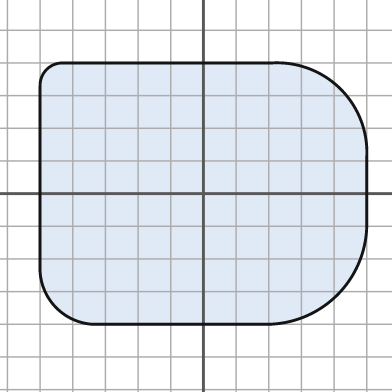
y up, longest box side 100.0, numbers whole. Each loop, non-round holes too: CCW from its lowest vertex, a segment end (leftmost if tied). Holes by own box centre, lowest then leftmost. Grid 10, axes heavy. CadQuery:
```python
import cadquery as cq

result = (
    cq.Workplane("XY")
    .moveTo(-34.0, -40.0)
    .lineTo(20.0, -40.0)
    .threePointArc((41.0, -31.0), (50.0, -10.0))
    .lineTo(50.0, 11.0)
    .threePointArc((42.0, 32.0), (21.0, 40.0))
    .lineTo(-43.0, 40.0)
    .threePointArc((-48.0, 38.0), (-50.0, 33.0))
    .lineTo(-50.0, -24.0)
    .threePointArc((-45.0, -35.0), (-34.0, -40.0))
    .close()
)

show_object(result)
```